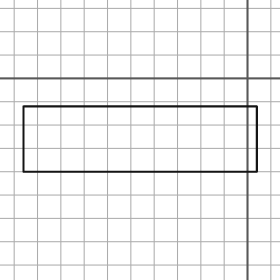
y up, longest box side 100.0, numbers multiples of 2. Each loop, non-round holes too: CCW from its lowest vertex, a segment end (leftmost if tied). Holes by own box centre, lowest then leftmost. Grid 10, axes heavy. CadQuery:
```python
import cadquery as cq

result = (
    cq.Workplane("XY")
    .moveTo(-96.0, -40.0)
    .lineTo(4.0, -40.0)
    .lineTo(4.0, -12.0)
    .lineTo(-96.0, -12.0)
    .close()
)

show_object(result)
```